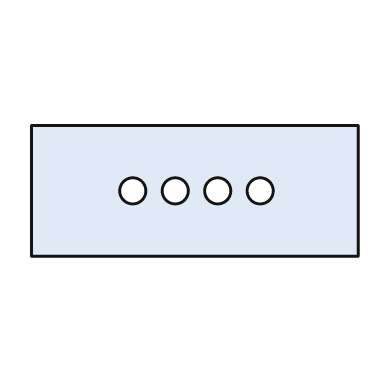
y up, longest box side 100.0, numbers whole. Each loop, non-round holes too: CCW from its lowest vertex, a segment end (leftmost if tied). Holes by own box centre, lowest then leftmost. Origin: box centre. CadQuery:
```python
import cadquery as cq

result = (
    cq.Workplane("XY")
    .moveTo(-50.0, -20.0)
    .lineTo(50.0, -20.0)
    .lineTo(50.0, 20.0)
    .lineTo(-50.0, 20.0)
    .close()
    .moveTo(-19.0, 0.0)
    .circle(4.0)
    .moveTo(-6.0, 0.0)
    .circle(4.0)
    .moveTo(7.0, 0.0)
    .circle(4.0)
    .moveTo(20.0, 0.0)
    .circle(4.0)
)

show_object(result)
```